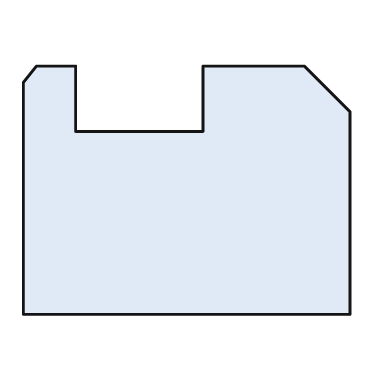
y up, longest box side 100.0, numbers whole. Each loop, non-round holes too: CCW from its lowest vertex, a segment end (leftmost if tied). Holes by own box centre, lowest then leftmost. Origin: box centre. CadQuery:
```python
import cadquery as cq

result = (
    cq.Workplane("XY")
    .moveTo(-50.0, -38.0)
    .lineTo(50.0, -38.0)
    .lineTo(50.0, 24.0)
    .lineTo(36.0, 38.0)
    .lineTo(5.0, 38.0)
    .lineTo(5.0, 18.0)
    .lineTo(-34.0, 18.0)
    .lineTo(-34.0, 38.0)
    .lineTo(-46.0, 38.0)
    .lineTo(-50.0, 33.0)
    .close()
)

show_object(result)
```